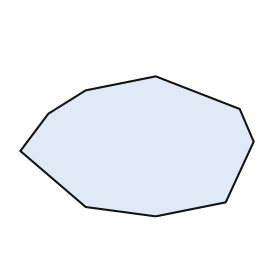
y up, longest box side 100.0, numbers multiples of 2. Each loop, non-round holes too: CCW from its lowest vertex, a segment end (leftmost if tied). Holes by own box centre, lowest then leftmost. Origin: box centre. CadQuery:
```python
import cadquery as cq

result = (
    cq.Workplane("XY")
    .moveTo(8.0, -30.0)
    .lineTo(38.0, -24.0)
    .lineTo(50.0, 2.0)
    .lineTo(44.0, 16.0)
    .lineTo(8.0, 30.0)
    .lineTo(-22.0, 24.0)
    .lineTo(-38.0, 14.0)
    .lineTo(-50.0, -2.0)
    .lineTo(-22.0, -26.0)
    .close()
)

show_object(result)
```